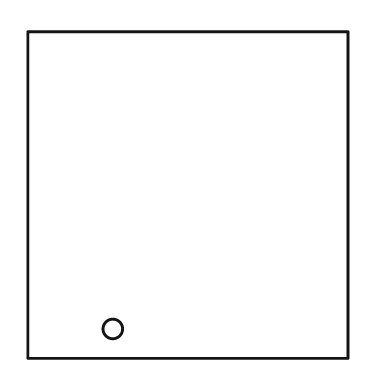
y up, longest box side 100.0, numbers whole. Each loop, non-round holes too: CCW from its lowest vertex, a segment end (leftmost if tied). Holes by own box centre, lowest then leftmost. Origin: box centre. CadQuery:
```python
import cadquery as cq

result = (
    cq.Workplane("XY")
    .moveTo(-49.0, -50.0)
    .lineTo(49.0, -50.0)
    .lineTo(49.0, 50.0)
    .lineTo(-49.0, 50.0)
    .close()
    .moveTo(-23.0, -41.0)
    .circle(3.0)
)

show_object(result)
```